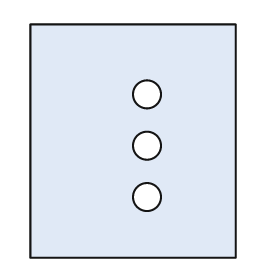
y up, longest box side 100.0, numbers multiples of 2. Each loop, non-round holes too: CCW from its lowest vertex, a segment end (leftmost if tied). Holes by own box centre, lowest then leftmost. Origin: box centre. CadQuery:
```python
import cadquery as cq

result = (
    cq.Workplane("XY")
    .moveTo(-44.0, -50.0)
    .lineTo(44.0, -50.0)
    .lineTo(44.0, 50.0)
    .lineTo(-44.0, 50.0)
    .close()
    .moveTo(6.0, -24.0)
    .circle(6.0)
    .moveTo(6.0, -2.0)
    .circle(6.0)
    .moveTo(6.0, 20.0)
    .circle(6.0)
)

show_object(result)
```